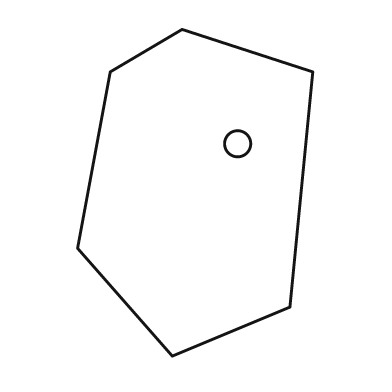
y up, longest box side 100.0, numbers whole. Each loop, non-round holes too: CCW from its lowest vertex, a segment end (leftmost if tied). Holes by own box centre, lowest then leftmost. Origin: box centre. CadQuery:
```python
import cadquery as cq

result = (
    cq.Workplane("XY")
    .moveTo(-7.0, -50.0)
    .lineTo(29.0, -35.0)
    .lineTo(36.0, 37.0)
    .lineTo(-4.0, 50.0)
    .lineTo(-26.0, 37.0)
    .lineTo(-36.0, -17.0)
    .close()
    .moveTo(13.0, 15.0)
    .circle(4.0)
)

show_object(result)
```